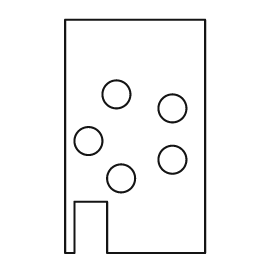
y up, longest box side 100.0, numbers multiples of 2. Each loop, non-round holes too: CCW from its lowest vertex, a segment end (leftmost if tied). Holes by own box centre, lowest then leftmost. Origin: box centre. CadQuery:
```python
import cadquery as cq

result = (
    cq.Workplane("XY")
    .moveTo(-30.0, -50.0)
    .lineTo(-26.0, -50.0)
    .lineTo(-26.0, -28.0)
    .lineTo(-12.0, -28.0)
    .lineTo(-12.0, -50.0)
    .lineTo(30.0, -50.0)
    .lineTo(30.0, 50.0)
    .lineTo(-30.0, 50.0)
    .close()
    .moveTo(-6.0, -18.0)
    .circle(6.0)
    .moveTo(16.0, -10.0)
    .circle(6.0)
    .moveTo(-20.0, -2.0)
    .circle(6.0)
    .moveTo(16.0, 12.0)
    .circle(6.0)
    .moveTo(-8.0, 18.0)
    .circle(6.0)
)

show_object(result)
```